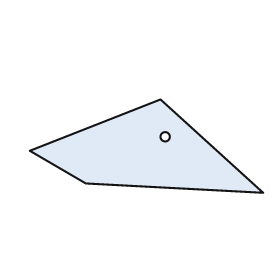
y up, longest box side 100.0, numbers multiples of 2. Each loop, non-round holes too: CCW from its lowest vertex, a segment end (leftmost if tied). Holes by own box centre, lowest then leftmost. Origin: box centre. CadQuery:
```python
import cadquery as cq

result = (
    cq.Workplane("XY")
    .moveTo(50.0, -20.0)
    .lineTo(6.0, 20.0)
    .lineTo(-50.0, -2.0)
    .lineTo(-26.0, -16.0)
    .close()
    .moveTo(8.0, 4.0)
    .circle(2.0)
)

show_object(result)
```